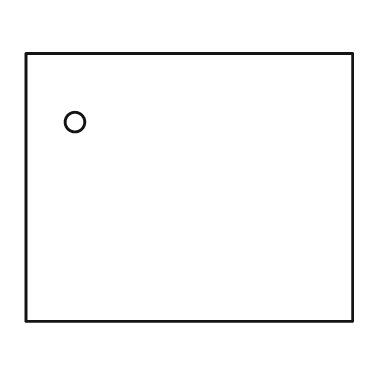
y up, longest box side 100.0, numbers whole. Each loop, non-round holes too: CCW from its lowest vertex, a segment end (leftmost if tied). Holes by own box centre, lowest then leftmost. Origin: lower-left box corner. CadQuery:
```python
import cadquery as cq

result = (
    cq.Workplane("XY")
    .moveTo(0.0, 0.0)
    .lineTo(100.0, 0.0)
    .lineTo(100.0, 82.0)
    .lineTo(0.0, 82.0)
    .close()
    .moveTo(15.0, 61.0)
    .circle(3.0)
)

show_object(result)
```